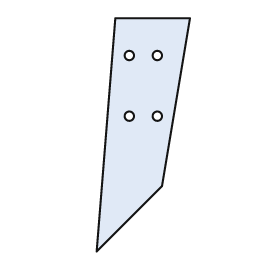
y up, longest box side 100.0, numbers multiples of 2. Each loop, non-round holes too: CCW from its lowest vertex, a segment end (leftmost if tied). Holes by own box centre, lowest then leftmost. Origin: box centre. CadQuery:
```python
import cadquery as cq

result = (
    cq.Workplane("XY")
    .moveTo(-20.0, -50.0)
    .lineTo(8.0, -22.0)
    .lineTo(20.0, 50.0)
    .lineTo(-12.0, 50.0)
    .close()
    .moveTo(-6.0, 8.0)
    .circle(2.0)
    .moveTo(6.0, 8.0)
    .circle(2.0)
    .moveTo(-6.0, 34.0)
    .circle(2.0)
    .moveTo(6.0, 34.0)
    .circle(2.0)
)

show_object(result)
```